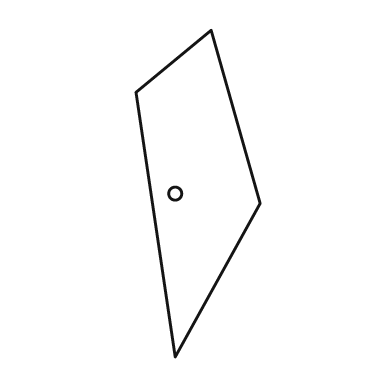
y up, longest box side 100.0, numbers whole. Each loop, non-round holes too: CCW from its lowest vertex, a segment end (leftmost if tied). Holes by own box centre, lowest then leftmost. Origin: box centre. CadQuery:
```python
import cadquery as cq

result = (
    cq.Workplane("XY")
    .moveTo(-7.0, -50.0)
    .lineTo(19.0, -3.0)
    .lineTo(4.0, 50.0)
    .lineTo(-19.0, 31.0)
    .close()
    .moveTo(-7.0, 0.0)
    .circle(2.0)
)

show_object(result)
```